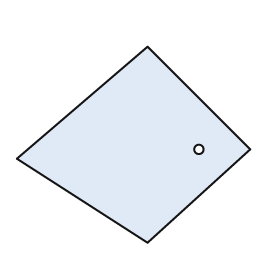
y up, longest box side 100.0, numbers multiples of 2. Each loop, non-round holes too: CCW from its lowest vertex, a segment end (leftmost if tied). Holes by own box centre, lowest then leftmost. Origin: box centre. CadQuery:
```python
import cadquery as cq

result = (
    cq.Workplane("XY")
    .moveTo(6.0, -42.0)
    .lineTo(50.0, -2.0)
    .lineTo(6.0, 42.0)
    .lineTo(-50.0, -6.0)
    .close()
    .moveTo(28.0, -2.0)
    .circle(2.0)
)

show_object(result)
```